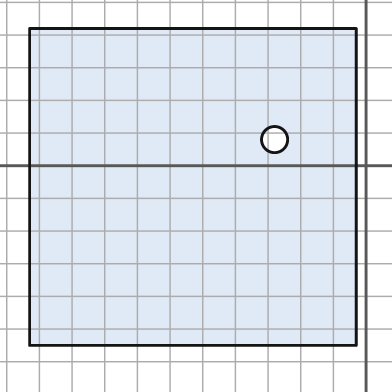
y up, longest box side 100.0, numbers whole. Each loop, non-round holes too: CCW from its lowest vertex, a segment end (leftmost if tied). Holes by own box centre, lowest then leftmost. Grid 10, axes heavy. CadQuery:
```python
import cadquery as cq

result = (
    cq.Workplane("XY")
    .moveTo(-103.0, -55.0)
    .lineTo(-3.0, -55.0)
    .lineTo(-3.0, 42.0)
    .lineTo(-103.0, 42.0)
    .close()
    .moveTo(-28.0, 8.0)
    .circle(4.0)
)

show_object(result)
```